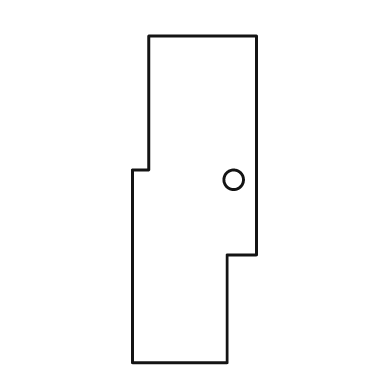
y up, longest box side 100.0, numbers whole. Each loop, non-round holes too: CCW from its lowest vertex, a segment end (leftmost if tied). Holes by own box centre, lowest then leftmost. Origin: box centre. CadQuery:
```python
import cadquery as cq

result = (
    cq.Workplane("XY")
    .moveTo(-19.0, -50.0)
    .lineTo(10.0, -50.0)
    .lineTo(10.0, -17.0)
    .lineTo(19.0, -17.0)
    .lineTo(19.0, 50.0)
    .lineTo(-14.0, 50.0)
    .lineTo(-14.0, 9.0)
    .lineTo(-19.0, 9.0)
    .close()
    .moveTo(12.0, 6.0)
    .circle(3.0)
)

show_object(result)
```